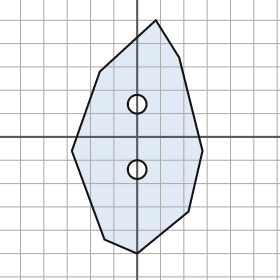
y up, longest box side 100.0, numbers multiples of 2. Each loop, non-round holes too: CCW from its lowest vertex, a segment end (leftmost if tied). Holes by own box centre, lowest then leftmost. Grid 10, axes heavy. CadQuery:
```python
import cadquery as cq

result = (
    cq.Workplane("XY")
    .moveTo(0.0, -50.0)
    .lineTo(22.0, -32.0)
    .lineTo(28.0, -6.0)
    .lineTo(18.0, 34.0)
    .lineTo(8.0, 50.0)
    .lineTo(-16.0, 28.0)
    .lineTo(-28.0, -6.0)
    .lineTo(-14.0, -44.0)
    .close()
    .moveTo(0.0, -14.0)
    .circle(4.0)
    .moveTo(0.0, 14.0)
    .circle(4.0)
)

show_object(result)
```